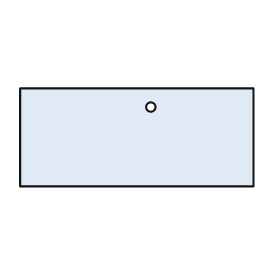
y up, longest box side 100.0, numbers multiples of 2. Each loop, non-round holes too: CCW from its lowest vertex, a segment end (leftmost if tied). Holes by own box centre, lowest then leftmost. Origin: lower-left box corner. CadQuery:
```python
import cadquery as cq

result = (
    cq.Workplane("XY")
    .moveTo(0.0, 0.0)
    .lineTo(100.0, 0.0)
    .lineTo(100.0, 42.0)
    .lineTo(0.0, 42.0)
    .close()
    .moveTo(56.0, 34.0)
    .circle(2.0)
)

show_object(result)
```